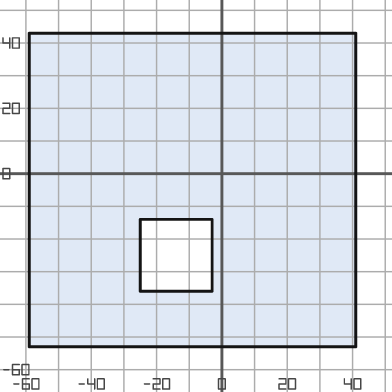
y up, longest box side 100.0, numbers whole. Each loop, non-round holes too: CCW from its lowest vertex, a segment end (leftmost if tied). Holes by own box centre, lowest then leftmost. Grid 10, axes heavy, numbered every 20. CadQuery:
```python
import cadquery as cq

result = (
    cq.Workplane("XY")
    .moveTo(-59.0, -53.0)
    .lineTo(41.0, -53.0)
    .lineTo(41.0, 43.0)
    .lineTo(-59.0, 43.0)
    .close()
    .moveTo(-25.0, -36.0)
    .lineTo(-3.0, -36.0)
    .lineTo(-3.0, -14.0)
    .lineTo(-25.0, -14.0)
    .close()
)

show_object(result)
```